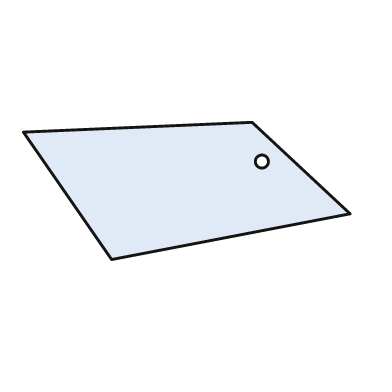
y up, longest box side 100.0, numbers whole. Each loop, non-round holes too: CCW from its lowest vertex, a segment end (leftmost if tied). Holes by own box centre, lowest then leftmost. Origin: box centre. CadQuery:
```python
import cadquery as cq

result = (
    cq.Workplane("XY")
    .moveTo(-23.0, -21.0)
    .lineTo(50.0, -7.0)
    .lineTo(20.0, 21.0)
    .lineTo(-50.0, 18.0)
    .close()
    .moveTo(23.0, 9.0)
    .circle(2.0)
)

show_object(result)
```